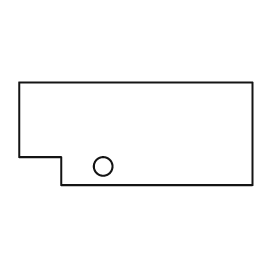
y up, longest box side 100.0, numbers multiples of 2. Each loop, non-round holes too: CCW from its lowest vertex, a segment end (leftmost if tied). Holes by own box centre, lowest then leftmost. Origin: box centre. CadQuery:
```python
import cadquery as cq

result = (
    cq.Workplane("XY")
    .moveTo(-32.0, -22.0)
    .lineTo(50.0, -22.0)
    .lineTo(50.0, 22.0)
    .lineTo(-50.0, 22.0)
    .lineTo(-50.0, -10.0)
    .lineTo(-32.0, -10.0)
    .close()
    .moveTo(-14.0, -14.0)
    .circle(4.0)
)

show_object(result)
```